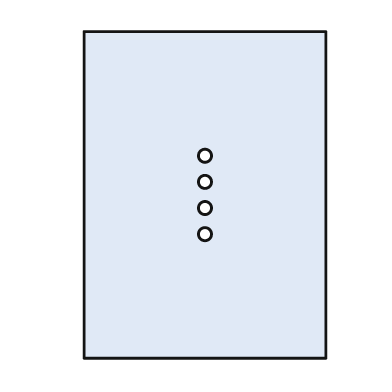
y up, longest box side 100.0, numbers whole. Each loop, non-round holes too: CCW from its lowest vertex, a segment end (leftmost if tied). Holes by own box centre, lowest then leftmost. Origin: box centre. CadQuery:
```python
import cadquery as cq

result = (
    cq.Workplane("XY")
    .moveTo(-37.0, -50.0)
    .lineTo(37.0, -50.0)
    .lineTo(37.0, 50.0)
    .lineTo(-37.0, 50.0)
    .close()
    .moveTo(0.0, -12.0)
    .circle(2.0)
    .moveTo(0.0, -4.0)
    .circle(2.0)
    .moveTo(0.0, 4.0)
    .circle(2.0)
    .moveTo(0.0, 12.0)
    .circle(2.0)
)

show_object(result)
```